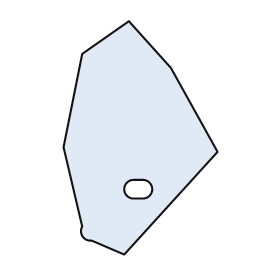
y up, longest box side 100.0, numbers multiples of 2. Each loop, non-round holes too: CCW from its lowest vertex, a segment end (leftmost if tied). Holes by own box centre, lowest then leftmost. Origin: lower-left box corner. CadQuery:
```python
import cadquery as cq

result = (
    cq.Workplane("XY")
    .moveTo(26.0, 0.0)
    .lineTo(66.0, 44.0)
    .lineTo(46.0, 80.0)
    .lineTo(28.0, 100.0)
    .lineTo(8.0, 86.0)
    .lineTo(0.0, 46.0)
    .lineTo(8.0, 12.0)
    .threePointArc((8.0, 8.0), (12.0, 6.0))
    .close()
    .moveTo(30.0, 24.0)
    .lineTo(34.0, 24.0)
    .threePointArc((38.0, 28.0), (34.0, 32.0))
    .lineTo(30.0, 32.0)
    .threePointArc((26.0, 28.0), (30.0, 24.0))
    .close()
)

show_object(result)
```